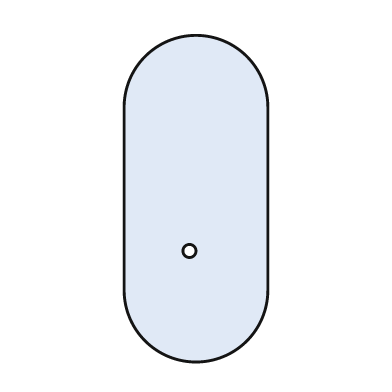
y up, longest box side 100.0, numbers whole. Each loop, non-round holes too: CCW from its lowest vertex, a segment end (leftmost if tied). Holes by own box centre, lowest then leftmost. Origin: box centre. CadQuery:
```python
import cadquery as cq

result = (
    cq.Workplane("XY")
    .moveTo(-22.0, -28.0)
    .threePointArc((0.0, -50.0), (22.0, -28.0))
    .lineTo(22.0, 28.0)
    .threePointArc((0.0, 50.0), (-22.0, 28.0))
    .close()
    .moveTo(-2.0, -16.0)
    .circle(2.0)
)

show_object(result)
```